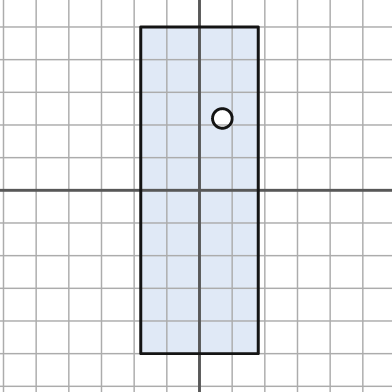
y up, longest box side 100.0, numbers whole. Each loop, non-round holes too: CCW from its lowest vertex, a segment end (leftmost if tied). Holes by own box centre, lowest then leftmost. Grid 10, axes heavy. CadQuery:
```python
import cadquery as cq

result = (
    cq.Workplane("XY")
    .moveTo(-18.0, -50.0)
    .lineTo(18.0, -50.0)
    .lineTo(18.0, 50.0)
    .lineTo(-18.0, 50.0)
    .close()
    .moveTo(7.0, 22.0)
    .circle(3.0)
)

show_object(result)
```